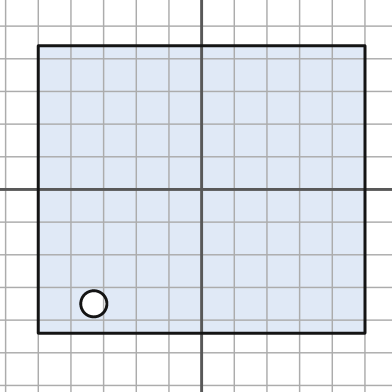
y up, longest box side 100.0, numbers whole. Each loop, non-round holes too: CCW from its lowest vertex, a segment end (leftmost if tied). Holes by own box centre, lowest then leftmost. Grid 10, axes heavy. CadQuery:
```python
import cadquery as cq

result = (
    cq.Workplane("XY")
    .moveTo(-50.0, -44.0)
    .lineTo(50.0, -44.0)
    .lineTo(50.0, 44.0)
    .lineTo(-50.0, 44.0)
    .close()
    .moveTo(-33.0, -35.0)
    .circle(4.0)
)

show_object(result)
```